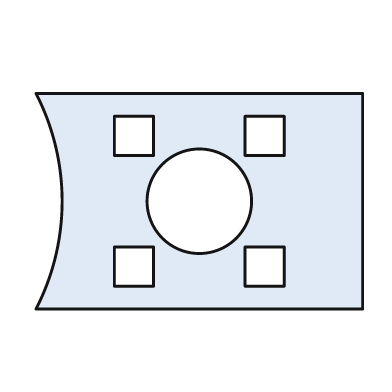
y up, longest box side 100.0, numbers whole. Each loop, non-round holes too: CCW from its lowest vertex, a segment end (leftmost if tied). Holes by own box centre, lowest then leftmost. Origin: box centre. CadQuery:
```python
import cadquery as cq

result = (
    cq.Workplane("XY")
    .moveTo(-50.0, -33.0)
    .lineTo(50.0, -33.0)
    .lineTo(50.0, 33.0)
    .lineTo(-50.0, 33.0)
    .threePointArc((-42.0, 0.0), (-50.0, -33.0))
    .close()
    .moveTo(-26.0, -26.0)
    .lineTo(-14.0, -26.0)
    .lineTo(-14.0, -14.0)
    .lineTo(-26.0, -14.0)
    .close()
    .moveTo(14.0, -26.0)
    .lineTo(26.0, -26.0)
    .lineTo(26.0, -14.0)
    .lineTo(14.0, -14.0)
    .close()
    .moveTo(0.0, 0.0)
    .circle(16.0)
    .moveTo(-26.0, 14.0)
    .lineTo(-14.0, 14.0)
    .lineTo(-14.0, 26.0)
    .lineTo(-26.0, 26.0)
    .close()
    .moveTo(14.0, 14.0)
    .lineTo(26.0, 14.0)
    .lineTo(26.0, 26.0)
    .lineTo(14.0, 26.0)
    .close()
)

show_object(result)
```